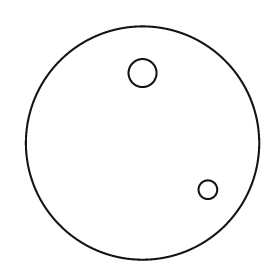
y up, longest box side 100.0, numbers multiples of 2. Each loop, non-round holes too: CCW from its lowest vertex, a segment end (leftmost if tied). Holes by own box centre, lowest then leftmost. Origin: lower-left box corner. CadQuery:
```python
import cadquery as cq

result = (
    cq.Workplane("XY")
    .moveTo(50.0, 50.0)
    .circle(50.0)
    .moveTo(78.0, 30.0)
    .circle(4.0)
    .moveTo(50.0, 80.0)
    .circle(6.0)
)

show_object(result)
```